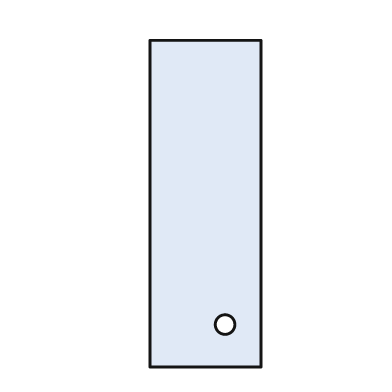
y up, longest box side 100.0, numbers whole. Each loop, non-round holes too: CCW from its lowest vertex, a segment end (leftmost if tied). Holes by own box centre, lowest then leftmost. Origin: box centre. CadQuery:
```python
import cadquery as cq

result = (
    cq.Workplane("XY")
    .moveTo(-17.0, -50.0)
    .lineTo(17.0, -50.0)
    .lineTo(17.0, 50.0)
    .lineTo(-17.0, 50.0)
    .close()
    .moveTo(6.0, -37.0)
    .circle(3.0)
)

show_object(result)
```